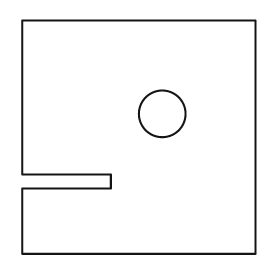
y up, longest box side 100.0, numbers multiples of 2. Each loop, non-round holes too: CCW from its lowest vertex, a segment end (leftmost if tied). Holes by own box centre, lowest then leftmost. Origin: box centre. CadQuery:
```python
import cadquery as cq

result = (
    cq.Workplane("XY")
    .moveTo(-50.0, -50.0)
    .lineTo(50.0, -50.0)
    .lineTo(50.0, 50.0)
    .lineTo(-50.0, 50.0)
    .lineTo(-50.0, -16.0)
    .lineTo(-12.0, -16.0)
    .lineTo(-12.0, -22.0)
    .lineTo(-50.0, -22.0)
    .close()
    .moveTo(10.0, 10.0)
    .circle(10.0)
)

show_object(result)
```